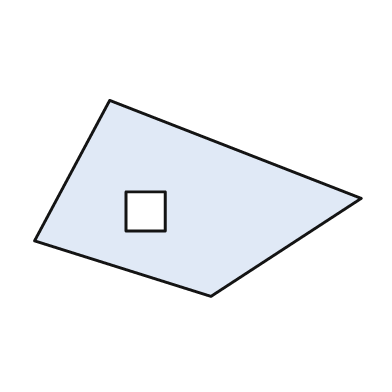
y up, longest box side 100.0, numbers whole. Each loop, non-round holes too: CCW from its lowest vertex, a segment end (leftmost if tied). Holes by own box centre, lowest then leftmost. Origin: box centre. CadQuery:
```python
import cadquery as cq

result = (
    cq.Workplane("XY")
    .moveTo(4.0, -30.0)
    .lineTo(50.0, 0.0)
    .lineTo(-27.0, 30.0)
    .lineTo(-50.0, -13.0)
    .close()
    .moveTo(-22.0, -10.0)
    .lineTo(-10.0, -10.0)
    .lineTo(-10.0, 2.0)
    .lineTo(-22.0, 2.0)
    .close()
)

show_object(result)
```